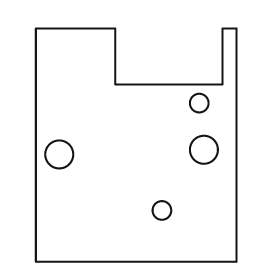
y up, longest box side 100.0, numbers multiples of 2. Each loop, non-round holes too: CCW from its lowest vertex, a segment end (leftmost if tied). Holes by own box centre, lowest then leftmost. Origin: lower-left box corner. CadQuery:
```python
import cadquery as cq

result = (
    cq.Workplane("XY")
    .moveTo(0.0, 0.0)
    .lineTo(86.0, 0.0)
    .lineTo(86.0, 100.0)
    .lineTo(80.0, 100.0)
    .lineTo(80.0, 76.0)
    .lineTo(34.0, 76.0)
    .lineTo(34.0, 100.0)
    .lineTo(0.0, 100.0)
    .close()
    .moveTo(54.0, 22.0)
    .circle(4.0)
    .moveTo(10.0, 46.0)
    .circle(6.0)
    .moveTo(72.0, 48.0)
    .circle(6.0)
    .moveTo(70.0, 68.0)
    .circle(4.0)
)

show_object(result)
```